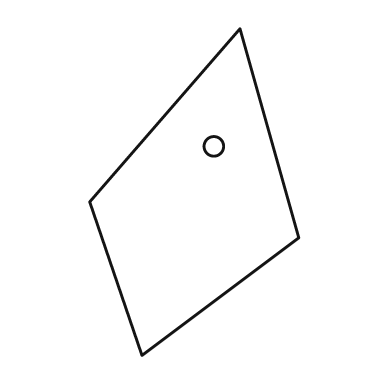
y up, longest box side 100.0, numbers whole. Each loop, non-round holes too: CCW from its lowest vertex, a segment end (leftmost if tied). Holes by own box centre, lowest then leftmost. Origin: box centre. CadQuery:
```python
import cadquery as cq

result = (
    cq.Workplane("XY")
    .moveTo(-16.0, -50.0)
    .lineTo(32.0, -14.0)
    .lineTo(14.0, 50.0)
    .lineTo(-32.0, -3.0)
    .close()
    .moveTo(6.0, 14.0)
    .circle(3.0)
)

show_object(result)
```